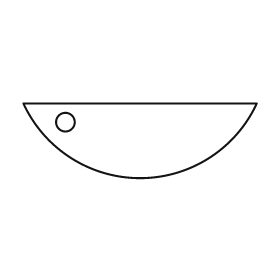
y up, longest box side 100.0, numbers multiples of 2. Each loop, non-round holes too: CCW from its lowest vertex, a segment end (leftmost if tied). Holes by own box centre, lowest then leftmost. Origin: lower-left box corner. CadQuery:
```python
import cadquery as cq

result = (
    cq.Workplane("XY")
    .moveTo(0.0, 32.0)
    .threePointArc((50.0, 0.0), (100.0, 32.0))
    .close()
    .moveTo(18.0, 24.0)
    .circle(4.0)
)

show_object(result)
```